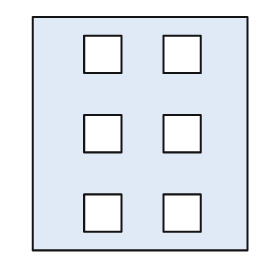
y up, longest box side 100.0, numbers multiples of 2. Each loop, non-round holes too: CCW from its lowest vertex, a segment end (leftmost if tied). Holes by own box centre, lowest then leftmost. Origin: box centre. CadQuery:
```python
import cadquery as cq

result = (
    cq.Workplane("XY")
    .moveTo(-46.0, -50.0)
    .lineTo(46.0, -50.0)
    .lineTo(46.0, 50.0)
    .lineTo(-46.0, 50.0)
    .close()
    .moveTo(-24.0, -42.0)
    .lineTo(-8.0, -42.0)
    .lineTo(-8.0, -26.0)
    .lineTo(-24.0, -26.0)
    .close()
    .moveTo(10.0, -42.0)
    .lineTo(26.0, -42.0)
    .lineTo(26.0, -26.0)
    .lineTo(10.0, -26.0)
    .close()
    .moveTo(-24.0, -8.0)
    .lineTo(-8.0, -8.0)
    .lineTo(-8.0, 8.0)
    .lineTo(-24.0, 8.0)
    .close()
    .moveTo(10.0, -8.0)
    .lineTo(26.0, -8.0)
    .lineTo(26.0, 8.0)
    .lineTo(10.0, 8.0)
    .close()
    .moveTo(-24.0, 26.0)
    .lineTo(-8.0, 26.0)
    .lineTo(-8.0, 42.0)
    .lineTo(-24.0, 42.0)
    .close()
    .moveTo(10.0, 26.0)
    .lineTo(26.0, 26.0)
    .lineTo(26.0, 42.0)
    .lineTo(10.0, 42.0)
    .close()
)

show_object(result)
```